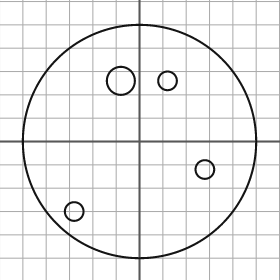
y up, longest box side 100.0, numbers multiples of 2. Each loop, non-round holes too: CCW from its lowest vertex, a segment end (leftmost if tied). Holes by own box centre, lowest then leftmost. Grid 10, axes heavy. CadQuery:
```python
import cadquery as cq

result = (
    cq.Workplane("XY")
    .moveTo(0.0, 0.0)
    .circle(50.0)
    .moveTo(-28.0, -30.0)
    .circle(4.0)
    .moveTo(28.0, -12.0)
    .circle(4.0)
    .moveTo(-8.0, 26.0)
    .circle(6.0)
    .moveTo(12.0, 26.0)
    .circle(4.0)
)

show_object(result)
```